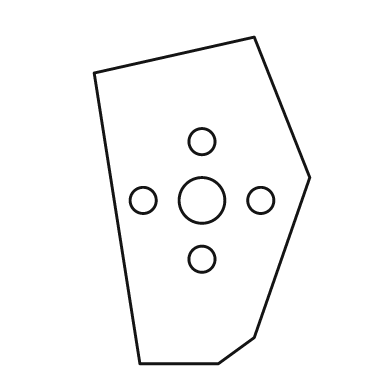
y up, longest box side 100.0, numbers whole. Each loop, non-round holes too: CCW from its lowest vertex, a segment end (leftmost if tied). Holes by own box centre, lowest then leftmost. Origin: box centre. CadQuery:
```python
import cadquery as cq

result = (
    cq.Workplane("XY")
    .moveTo(-19.0, -50.0)
    .lineTo(5.0, -50.0)
    .lineTo(16.0, -42.0)
    .lineTo(33.0, 7.0)
    .lineTo(16.0, 50.0)
    .lineTo(-33.0, 39.0)
    .close()
    .moveTo(0.0, -18.0)
    .circle(4.0)
    .moveTo(-18.0, 0.0)
    .circle(4.0)
    .moveTo(0.0, 0.0)
    .circle(7.0)
    .moveTo(18.0, 0.0)
    .circle(4.0)
    .moveTo(0.0, 18.0)
    .circle(4.0)
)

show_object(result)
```